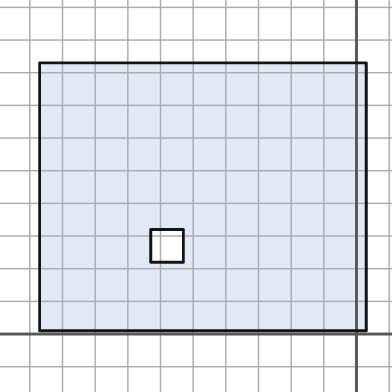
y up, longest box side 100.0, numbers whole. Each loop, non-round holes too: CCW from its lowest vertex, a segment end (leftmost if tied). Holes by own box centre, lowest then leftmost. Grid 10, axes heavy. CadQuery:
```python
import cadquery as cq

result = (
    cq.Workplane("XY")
    .moveTo(-97.0, 1.0)
    .lineTo(3.0, 1.0)
    .lineTo(3.0, 83.0)
    .lineTo(-97.0, 83.0)
    .close()
    .moveTo(-63.0, 22.0)
    .lineTo(-53.0, 22.0)
    .lineTo(-53.0, 32.0)
    .lineTo(-63.0, 32.0)
    .close()
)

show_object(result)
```